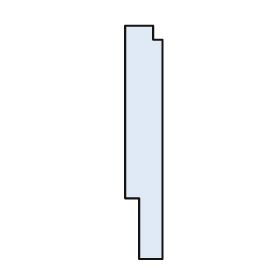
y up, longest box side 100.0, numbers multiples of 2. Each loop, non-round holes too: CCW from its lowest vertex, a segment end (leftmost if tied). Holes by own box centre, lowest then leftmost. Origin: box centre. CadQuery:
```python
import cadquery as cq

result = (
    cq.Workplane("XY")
    .moveTo(-2.0, -50.0)
    .lineTo(8.0, -50.0)
    .lineTo(8.0, 44.0)
    .lineTo(4.0, 44.0)
    .lineTo(4.0, 50.0)
    .lineTo(-8.0, 50.0)
    .lineTo(-8.0, -24.0)
    .lineTo(-2.0, -24.0)
    .close()
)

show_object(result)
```